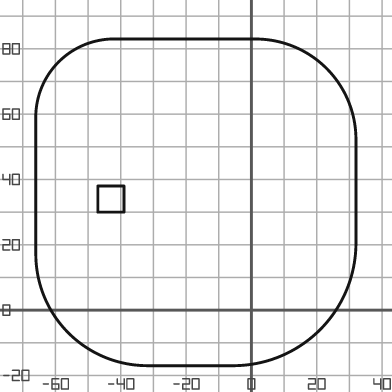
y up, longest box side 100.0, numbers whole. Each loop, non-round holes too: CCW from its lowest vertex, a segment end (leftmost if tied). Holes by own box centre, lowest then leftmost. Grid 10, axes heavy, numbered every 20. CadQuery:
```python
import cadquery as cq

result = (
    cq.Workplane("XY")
    .moveTo(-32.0, -17.0)
    .lineTo(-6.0, -17.0)
    .threePointArc((21.0, -6.0), (32.0, 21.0))
    .lineTo(32.0, 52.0)
    .threePointArc((23.0, 74.0), (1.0, 83.0))
    .lineTo(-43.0, 83.0)
    .threePointArc((-59.0, 76.0), (-66.0, 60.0))
    .lineTo(-66.0, 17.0)
    .threePointArc((-56.0, -7.0), (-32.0, -17.0))
    .close()
    .moveTo(-47.0, 30.0)
    .lineTo(-39.0, 30.0)
    .lineTo(-39.0, 38.0)
    .lineTo(-47.0, 38.0)
    .close()
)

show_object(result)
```